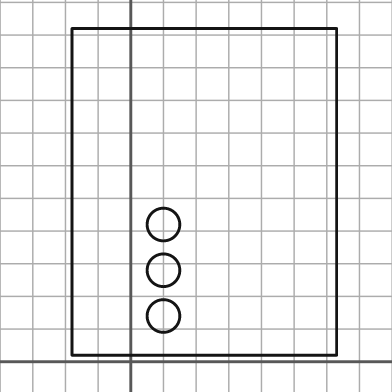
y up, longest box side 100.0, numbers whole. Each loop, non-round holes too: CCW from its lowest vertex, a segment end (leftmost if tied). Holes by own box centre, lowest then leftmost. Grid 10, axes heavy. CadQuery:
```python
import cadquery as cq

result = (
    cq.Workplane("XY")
    .moveTo(-18.0, 2.0)
    .lineTo(63.0, 2.0)
    .lineTo(63.0, 102.0)
    .lineTo(-18.0, 102.0)
    .close()
    .moveTo(10.0, 14.0)
    .circle(5.0)
    .moveTo(10.0, 28.0)
    .circle(5.0)
    .moveTo(10.0, 42.0)
    .circle(5.0)
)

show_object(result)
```